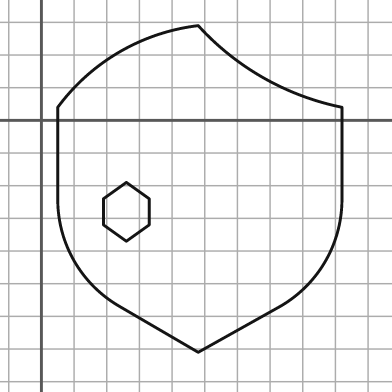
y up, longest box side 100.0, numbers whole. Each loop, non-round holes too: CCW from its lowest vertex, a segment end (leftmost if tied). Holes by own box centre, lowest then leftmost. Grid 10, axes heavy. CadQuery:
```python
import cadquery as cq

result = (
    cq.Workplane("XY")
    .moveTo(48.0, -71.0)
    .lineTo(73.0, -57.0)
    .threePointArc((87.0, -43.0), (92.0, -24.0))
    .lineTo(92.0, 4.0)
    .threePointArc((68.0, 13.0), (48.0, 29.0))
    .threePointArc((24.0, 21.0), (5.0, 4.0))
    .lineTo(5.0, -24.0)
    .threePointArc((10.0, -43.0), (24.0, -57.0))
    .close()
    .moveTo(26.0, -37.0)
    .lineTo(33.0, -32.0)
    .lineTo(33.0, -24.0)
    .lineTo(26.0, -19.0)
    .lineTo(19.0, -24.0)
    .lineTo(19.0, -32.0)
    .close()
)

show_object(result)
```